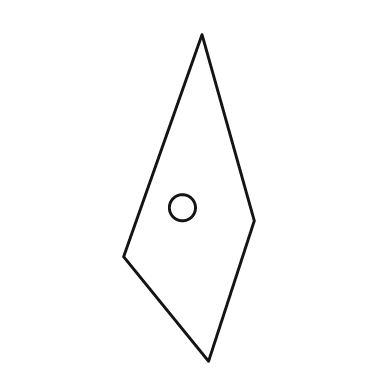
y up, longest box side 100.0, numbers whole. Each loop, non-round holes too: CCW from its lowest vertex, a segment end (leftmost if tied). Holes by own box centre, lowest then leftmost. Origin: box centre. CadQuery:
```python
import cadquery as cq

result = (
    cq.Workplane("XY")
    .moveTo(6.0, -50.0)
    .lineTo(20.0, -7.0)
    .lineTo(4.0, 50.0)
    .lineTo(-20.0, -18.0)
    .close()
    .moveTo(-2.0, -3.0)
    .circle(4.0)
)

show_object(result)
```